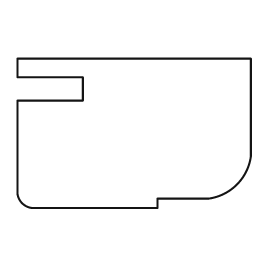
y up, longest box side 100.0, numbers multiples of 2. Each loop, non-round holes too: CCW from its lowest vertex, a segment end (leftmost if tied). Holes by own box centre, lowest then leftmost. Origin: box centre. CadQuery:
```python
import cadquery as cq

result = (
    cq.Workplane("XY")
    .moveTo(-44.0, -32.0)
    .lineTo(10.0, -32.0)
    .lineTo(10.0, -28.0)
    .lineTo(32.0, -28.0)
    .threePointArc((44.0, -22.0), (50.0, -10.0))
    .lineTo(50.0, 32.0)
    .lineTo(-50.0, 32.0)
    .lineTo(-50.0, 24.0)
    .lineTo(-22.0, 24.0)
    .lineTo(-22.0, 14.0)
    .lineTo(-50.0, 14.0)
    .lineTo(-50.0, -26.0)
    .threePointArc((-48.0, -30.0), (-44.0, -32.0))
    .close()
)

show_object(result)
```